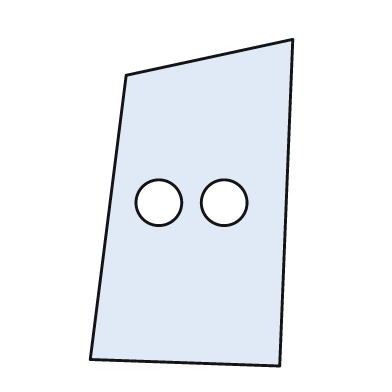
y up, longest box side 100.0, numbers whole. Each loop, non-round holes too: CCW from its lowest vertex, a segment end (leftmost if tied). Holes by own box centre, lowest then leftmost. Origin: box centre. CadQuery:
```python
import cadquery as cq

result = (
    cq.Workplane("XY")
    .moveTo(27.0, -50.0)
    .lineTo(31.0, 50.0)
    .lineTo(-20.0, 39.0)
    .lineTo(-31.0, -48.0)
    .close()
    .moveTo(-10.0, 0.0)
    .circle(7.0)
    .moveTo(10.0, 0.0)
    .circle(7.0)
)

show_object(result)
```